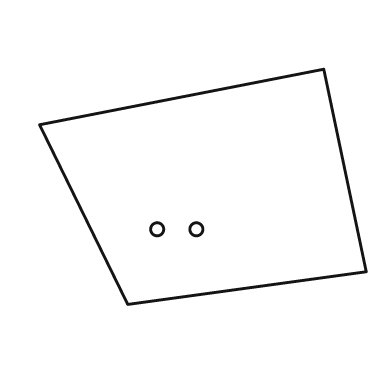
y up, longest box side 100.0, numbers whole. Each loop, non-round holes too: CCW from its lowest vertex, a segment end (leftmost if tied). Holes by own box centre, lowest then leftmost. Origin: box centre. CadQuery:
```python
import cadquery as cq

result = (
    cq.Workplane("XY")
    .moveTo(-23.0, -36.0)
    .lineTo(50.0, -26.0)
    .lineTo(37.0, 36.0)
    .lineTo(-50.0, 19.0)
    .close()
    .moveTo(-14.0, -13.0)
    .circle(2.0)
    .moveTo(-2.0, -13.0)
    .circle(2.0)
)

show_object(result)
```